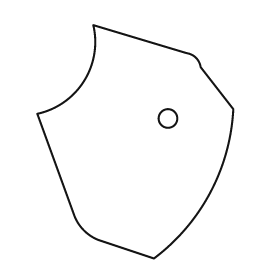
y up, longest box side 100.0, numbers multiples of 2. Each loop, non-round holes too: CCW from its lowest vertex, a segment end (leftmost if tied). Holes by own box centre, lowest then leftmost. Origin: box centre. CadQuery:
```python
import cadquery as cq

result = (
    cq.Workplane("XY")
    .moveTo(8.0, -50.0)
    .threePointArc((32.0, -22.0), (42.0, 14.0))
    .lineTo(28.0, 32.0)
    .threePointArc((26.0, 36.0), (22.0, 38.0))
    .lineTo(-18.0, 50.0)
    .threePointArc((-22.0, 26.0), (-42.0, 12.0))
    .lineTo(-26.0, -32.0)
    .threePointArc((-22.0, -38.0), (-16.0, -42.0))
    .close()
    .moveTo(14.0, 10.0)
    .circle(4.0)
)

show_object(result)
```